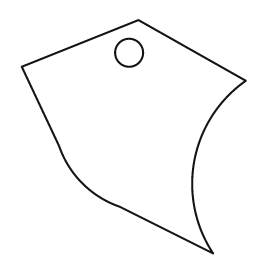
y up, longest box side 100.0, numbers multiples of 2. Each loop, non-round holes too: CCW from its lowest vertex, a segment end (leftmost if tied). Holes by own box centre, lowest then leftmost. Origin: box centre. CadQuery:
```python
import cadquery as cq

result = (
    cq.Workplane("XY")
    .moveTo(34.0, -50.0)
    .threePointArc((26.0, -10.0), (48.0, 24.0))
    .lineTo(2.0, 50.0)
    .lineTo(-48.0, 30.0)
    .lineTo(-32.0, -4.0)
    .threePointArc((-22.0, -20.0), (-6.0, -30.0))
    .close()
    .moveTo(-2.0, 36.0)
    .circle(6.0)
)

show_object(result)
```